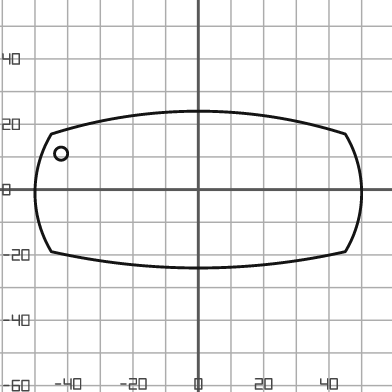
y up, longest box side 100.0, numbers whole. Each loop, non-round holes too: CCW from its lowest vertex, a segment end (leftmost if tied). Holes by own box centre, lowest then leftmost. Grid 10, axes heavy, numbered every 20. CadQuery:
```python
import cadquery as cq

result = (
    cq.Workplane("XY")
    .moveTo(-45.0, -19.0)
    .threePointArc((0.0, -24.0), (45.0, -19.0))
    .threePointArc((50.0, -1.0), (45.0, 17.0))
    .threePointArc((0.0, 24.0), (-45.0, 17.0))
    .threePointArc((-50.0, -1.0), (-45.0, -19.0))
    .close()
    .moveTo(-42.0, 11.0)
    .circle(2.0)
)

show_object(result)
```